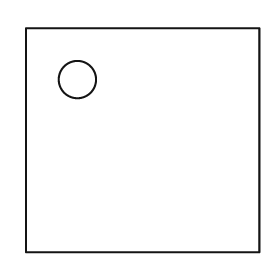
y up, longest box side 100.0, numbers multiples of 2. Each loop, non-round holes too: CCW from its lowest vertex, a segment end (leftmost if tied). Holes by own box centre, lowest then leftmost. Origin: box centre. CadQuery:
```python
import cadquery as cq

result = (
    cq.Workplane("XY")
    .moveTo(-50.0, -48.0)
    .lineTo(50.0, -48.0)
    .lineTo(50.0, 48.0)
    .lineTo(-50.0, 48.0)
    .close()
    .moveTo(-28.0, 26.0)
    .circle(8.0)
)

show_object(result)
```